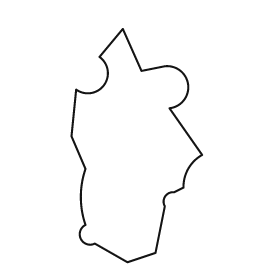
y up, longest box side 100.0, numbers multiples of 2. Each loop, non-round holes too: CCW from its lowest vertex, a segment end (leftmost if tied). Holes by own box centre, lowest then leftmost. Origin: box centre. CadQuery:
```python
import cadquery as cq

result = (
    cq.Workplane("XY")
    .moveTo(-4.0, -50.0)
    .lineTo(8.0, -46.0)
    .lineTo(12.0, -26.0)
    .threePointArc((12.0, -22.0), (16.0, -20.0))
    .lineTo(20.0, -18.0)
    .threePointArc((22.0, -10.0), (28.0, -4.0))
    .lineTo(14.0, 16.0)
    .threePointArc((22.0, 26.0), (12.0, 34.0))
    .lineTo(2.0, 32.0)
    .lineTo(-6.0, 50.0)
    .lineTo(-16.0, 38.0)
    .threePointArc((-14.0, 26.0), (-26.0, 24.0))
    .lineTo(-28.0, 4.0)
    .lineTo(-22.0, -10.0)
    .threePointArc((-24.0, -22.0), (-22.0, -34.0))
    .threePointArc((-24.0, -40.0), (-18.0, -42.0))
    .close()
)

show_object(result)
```